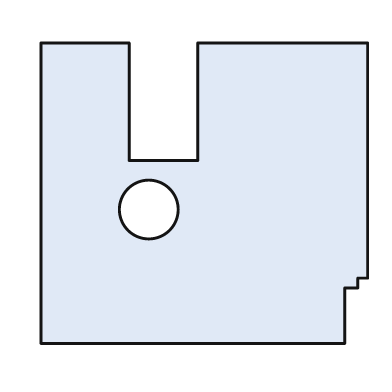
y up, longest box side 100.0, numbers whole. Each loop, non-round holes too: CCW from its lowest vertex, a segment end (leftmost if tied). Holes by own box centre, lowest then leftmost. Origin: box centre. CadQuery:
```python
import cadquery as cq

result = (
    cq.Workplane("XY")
    .moveTo(-50.0, -46.0)
    .lineTo(43.0, -46.0)
    .lineTo(43.0, -29.0)
    .lineTo(47.0, -29.0)
    .lineTo(47.0, -26.0)
    .lineTo(50.0, -26.0)
    .lineTo(50.0, 46.0)
    .lineTo(-2.0, 46.0)
    .lineTo(-2.0, 10.0)
    .lineTo(-23.0, 10.0)
    .lineTo(-23.0, 46.0)
    .lineTo(-50.0, 46.0)
    .close()
    .moveTo(-17.0, -5.0)
    .circle(9.0)
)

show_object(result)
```